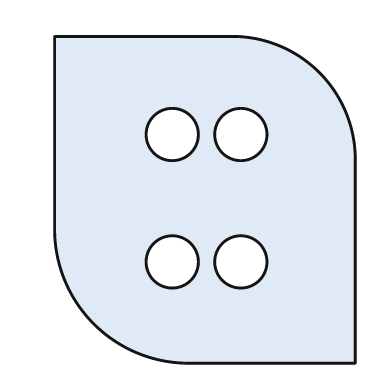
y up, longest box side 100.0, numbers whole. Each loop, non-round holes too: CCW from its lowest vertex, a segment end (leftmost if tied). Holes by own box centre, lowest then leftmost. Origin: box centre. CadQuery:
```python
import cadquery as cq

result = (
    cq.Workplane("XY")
    .moveTo(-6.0, -50.0)
    .lineTo(46.0, -50.0)
    .lineTo(46.0, 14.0)
    .threePointArc((35.0, 39.0), (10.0, 50.0))
    .lineTo(-46.0, 50.0)
    .lineTo(-46.0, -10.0)
    .threePointArc((-34.0, -38.0), (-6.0, -50.0))
    .close()
    .moveTo(-10.0, -19.0)
    .circle(8.0)
    .moveTo(11.0, -19.0)
    .circle(8.0)
    .moveTo(-10.0, 20.0)
    .circle(8.0)
    .moveTo(11.0, 20.0)
    .circle(8.0)
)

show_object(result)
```